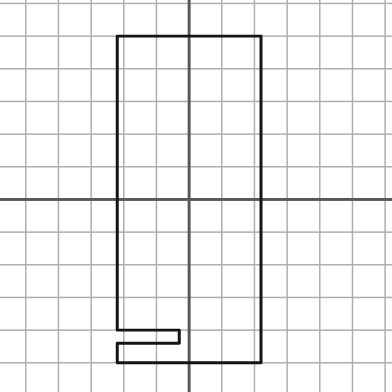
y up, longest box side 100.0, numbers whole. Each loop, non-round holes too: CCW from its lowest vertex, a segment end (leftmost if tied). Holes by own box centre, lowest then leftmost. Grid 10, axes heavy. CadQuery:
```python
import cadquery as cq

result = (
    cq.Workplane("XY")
    .moveTo(-22.0, -50.0)
    .lineTo(22.0, -50.0)
    .lineTo(22.0, 50.0)
    .lineTo(-22.0, 50.0)
    .lineTo(-22.0, -40.0)
    .lineTo(-3.0, -40.0)
    .lineTo(-3.0, -44.0)
    .lineTo(-22.0, -44.0)
    .close()
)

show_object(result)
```